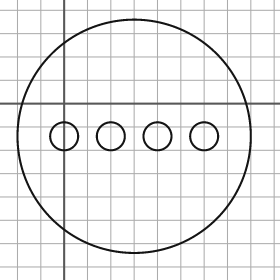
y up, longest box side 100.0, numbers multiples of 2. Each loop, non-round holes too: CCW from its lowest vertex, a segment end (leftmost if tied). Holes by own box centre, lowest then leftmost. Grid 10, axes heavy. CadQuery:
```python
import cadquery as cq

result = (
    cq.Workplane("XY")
    .moveTo(30.0, -14.0)
    .circle(50.0)
    .moveTo(0.0, -14.0)
    .circle(6.0)
    .moveTo(20.0, -14.0)
    .circle(6.0)
    .moveTo(40.0, -14.0)
    .circle(6.0)
    .moveTo(60.0, -14.0)
    .circle(6.0)
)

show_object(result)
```